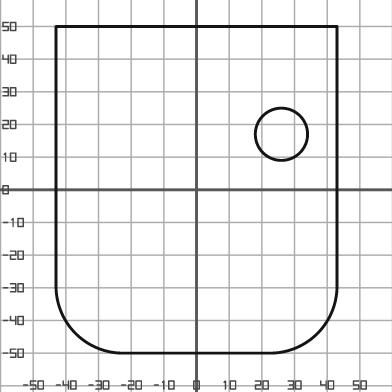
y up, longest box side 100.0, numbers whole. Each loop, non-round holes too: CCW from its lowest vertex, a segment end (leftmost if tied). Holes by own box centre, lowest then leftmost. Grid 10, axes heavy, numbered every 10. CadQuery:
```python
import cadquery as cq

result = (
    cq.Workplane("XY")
    .moveTo(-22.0, -50.0)
    .lineTo(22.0, -50.0)
    .threePointArc((37.0, -44.0), (43.0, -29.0))
    .lineTo(43.0, 50.0)
    .lineTo(-43.0, 50.0)
    .lineTo(-43.0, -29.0)
    .threePointArc((-37.0, -44.0), (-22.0, -50.0))
    .close()
    .moveTo(26.0, 17.0)
    .circle(8.0)
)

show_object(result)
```